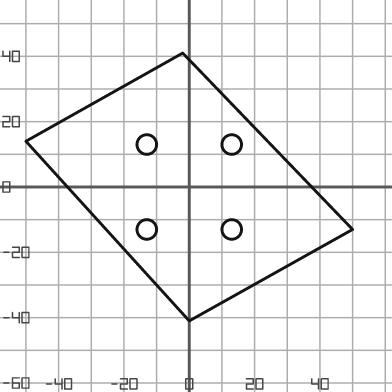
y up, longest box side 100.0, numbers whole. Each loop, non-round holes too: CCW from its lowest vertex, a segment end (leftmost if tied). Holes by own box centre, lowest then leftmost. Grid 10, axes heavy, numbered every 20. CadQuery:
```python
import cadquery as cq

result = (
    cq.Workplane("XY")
    .moveTo(0.0, -41.0)
    .lineTo(50.0, -13.0)
    .lineTo(-2.0, 41.0)
    .lineTo(-50.0, 14.0)
    .close()
    .moveTo(-13.0, -13.0)
    .circle(3.0)
    .moveTo(13.0, -13.0)
    .circle(3.0)
    .moveTo(-13.0, 13.0)
    .circle(3.0)
    .moveTo(13.0, 13.0)
    .circle(3.0)
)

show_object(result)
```